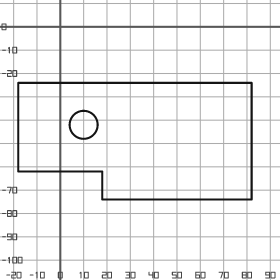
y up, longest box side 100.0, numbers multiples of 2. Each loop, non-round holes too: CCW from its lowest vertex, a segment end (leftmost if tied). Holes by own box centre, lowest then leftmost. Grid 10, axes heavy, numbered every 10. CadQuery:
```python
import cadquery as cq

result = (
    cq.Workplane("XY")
    .moveTo(18.0, -74.0)
    .lineTo(82.0, -74.0)
    .lineTo(82.0, -24.0)
    .lineTo(-18.0, -24.0)
    .lineTo(-18.0, -62.0)
    .lineTo(18.0, -62.0)
    .close()
    .moveTo(10.0, -42.0)
    .circle(6.0)
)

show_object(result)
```